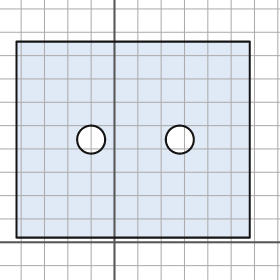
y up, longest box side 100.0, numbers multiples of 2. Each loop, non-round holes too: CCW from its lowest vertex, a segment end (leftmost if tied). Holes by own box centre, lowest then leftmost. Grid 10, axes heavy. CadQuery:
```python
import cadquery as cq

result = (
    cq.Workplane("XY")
    .moveTo(-42.0, 2.0)
    .lineTo(58.0, 2.0)
    .lineTo(58.0, 86.0)
    .lineTo(-42.0, 86.0)
    .close()
    .moveTo(-10.0, 44.0)
    .circle(6.0)
    .moveTo(28.0, 44.0)
    .circle(6.0)
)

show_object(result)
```